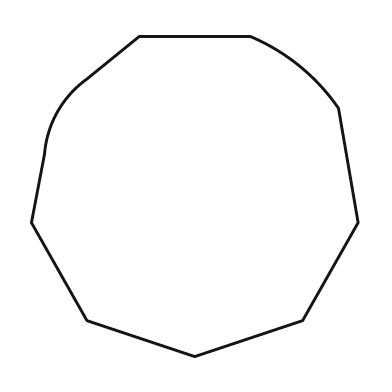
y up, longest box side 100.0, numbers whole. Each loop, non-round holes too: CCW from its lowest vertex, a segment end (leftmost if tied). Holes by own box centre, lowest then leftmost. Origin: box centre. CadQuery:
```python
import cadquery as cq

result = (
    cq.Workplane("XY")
    .moveTo(0.0, -49.0)
    .lineTo(33.0, -38.0)
    .lineTo(50.0, -8.0)
    .lineTo(44.0, 27.0)
    .threePointArc((32.0, 40.0), (17.0, 49.0))
    .lineTo(-17.0, 49.0)
    .lineTo(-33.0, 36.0)
    .threePointArc((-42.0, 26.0), (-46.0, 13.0))
    .lineTo(-50.0, -8.0)
    .lineTo(-33.0, -38.0)
    .close()
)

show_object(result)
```